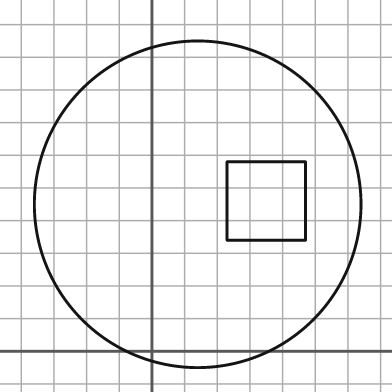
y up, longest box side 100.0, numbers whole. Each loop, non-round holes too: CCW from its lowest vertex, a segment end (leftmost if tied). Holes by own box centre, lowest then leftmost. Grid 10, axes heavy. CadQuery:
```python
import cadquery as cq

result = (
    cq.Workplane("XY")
    .moveTo(14.0, 45.0)
    .circle(50.0)
    .moveTo(23.0, 34.0)
    .lineTo(47.0, 34.0)
    .lineTo(47.0, 58.0)
    .lineTo(23.0, 58.0)
    .close()
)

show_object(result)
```